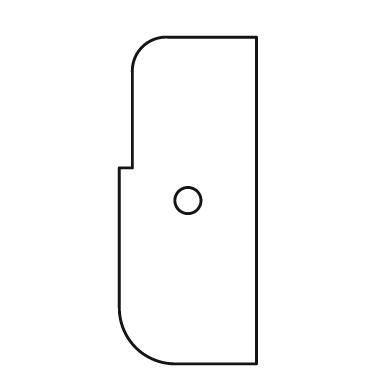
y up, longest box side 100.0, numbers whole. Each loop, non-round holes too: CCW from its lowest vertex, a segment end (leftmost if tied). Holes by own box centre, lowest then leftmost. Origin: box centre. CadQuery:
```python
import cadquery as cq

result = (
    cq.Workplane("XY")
    .moveTo(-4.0, -50.0)
    .lineTo(21.0, -50.0)
    .lineTo(21.0, 50.0)
    .lineTo(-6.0, 50.0)
    .threePointArc((-14.0, 47.0), (-17.0, 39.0))
    .lineTo(-17.0, 10.0)
    .lineTo(-21.0, 10.0)
    .lineTo(-21.0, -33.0)
    .threePointArc((-16.0, -45.0), (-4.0, -50.0))
    .close()
    .moveTo(0.0, 0.0)
    .circle(4.0)
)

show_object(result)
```